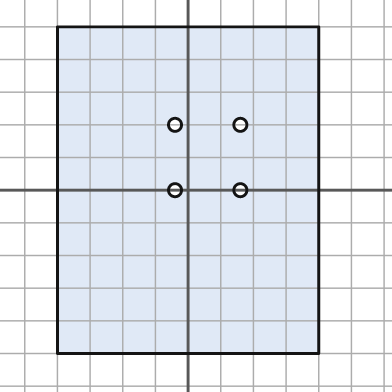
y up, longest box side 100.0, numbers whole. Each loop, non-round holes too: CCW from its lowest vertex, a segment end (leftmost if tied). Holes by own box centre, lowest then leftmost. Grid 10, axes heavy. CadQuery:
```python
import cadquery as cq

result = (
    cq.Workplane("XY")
    .moveTo(-40.0, -50.0)
    .lineTo(40.0, -50.0)
    .lineTo(40.0, 50.0)
    .lineTo(-40.0, 50.0)
    .close()
    .moveTo(-4.0, 0.0)
    .circle(2.0)
    .moveTo(16.0, 0.0)
    .circle(2.0)
    .moveTo(-4.0, 20.0)
    .circle(2.0)
    .moveTo(16.0, 20.0)
    .circle(2.0)
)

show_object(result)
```